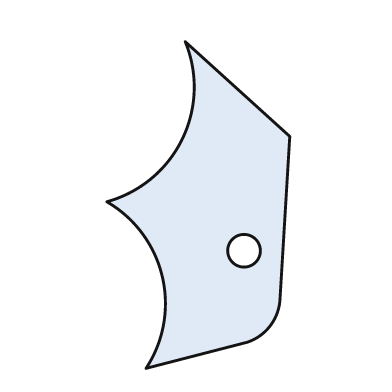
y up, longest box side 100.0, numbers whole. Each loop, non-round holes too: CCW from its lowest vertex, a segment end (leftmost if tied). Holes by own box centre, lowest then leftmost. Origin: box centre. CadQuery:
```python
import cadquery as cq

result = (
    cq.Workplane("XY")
    .moveTo(-16.0, -50.0)
    .lineTo(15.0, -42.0)
    .threePointArc((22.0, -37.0), (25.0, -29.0))
    .lineTo(28.0, 21.0)
    .lineTo(-4.0, 50.0)
    .threePointArc((-5.0, 20.0), (-28.0, 1.0))
    .threePointArc((-11.0, -22.0), (-16.0, -50.0))
    .close()
    .moveTo(14.0, -14.0)
    .circle(5.0)
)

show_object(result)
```